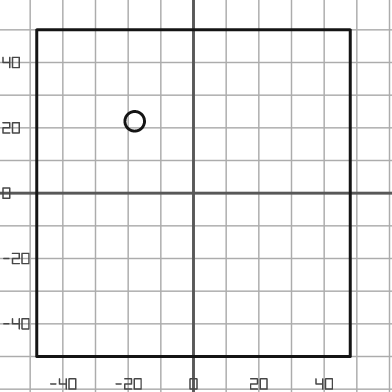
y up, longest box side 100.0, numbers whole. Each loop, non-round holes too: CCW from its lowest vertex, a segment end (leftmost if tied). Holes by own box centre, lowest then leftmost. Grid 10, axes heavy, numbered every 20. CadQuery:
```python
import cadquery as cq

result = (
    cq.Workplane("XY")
    .moveTo(-48.0, -50.0)
    .lineTo(48.0, -50.0)
    .lineTo(48.0, 50.0)
    .lineTo(-48.0, 50.0)
    .close()
    .moveTo(-18.0, 22.0)
    .circle(3.0)
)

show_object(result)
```